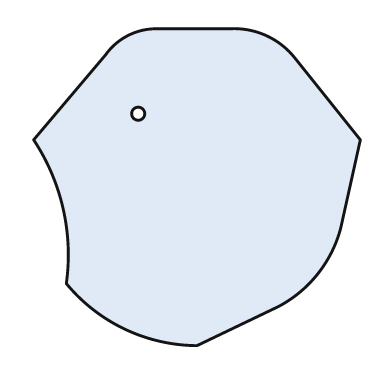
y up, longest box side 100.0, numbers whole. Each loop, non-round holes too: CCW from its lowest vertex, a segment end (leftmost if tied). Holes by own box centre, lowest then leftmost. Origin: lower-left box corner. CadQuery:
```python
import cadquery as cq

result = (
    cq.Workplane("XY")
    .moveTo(50.0, 0.0)
    .lineTo(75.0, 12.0)
    .threePointArc((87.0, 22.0), (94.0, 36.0))
    .lineTo(100.0, 63.0)
    .lineTo(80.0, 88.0)
    .threePointArc((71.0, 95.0), (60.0, 97.0))
    .lineTo(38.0, 97.0)
    .threePointArc((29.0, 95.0), (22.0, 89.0))
    .lineTo(0.0, 63.0)
    .threePointArc((9.0, 42.0), (10.0, 19.0))
    .threePointArc((28.0, 5.0), (50.0, 0.0))
    .close()
    .moveTo(32.0, 71.0)
    .circle(2.0)
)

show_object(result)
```